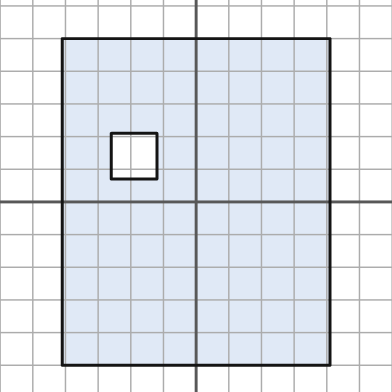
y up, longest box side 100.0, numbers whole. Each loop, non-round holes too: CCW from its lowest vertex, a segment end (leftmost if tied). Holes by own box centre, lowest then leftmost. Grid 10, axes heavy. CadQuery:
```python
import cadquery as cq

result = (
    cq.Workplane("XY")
    .moveTo(-41.0, -50.0)
    .lineTo(41.0, -50.0)
    .lineTo(41.0, 50.0)
    .lineTo(-41.0, 50.0)
    .close()
    .moveTo(-26.0, 7.0)
    .lineTo(-12.0, 7.0)
    .lineTo(-12.0, 21.0)
    .lineTo(-26.0, 21.0)
    .close()
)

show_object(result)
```